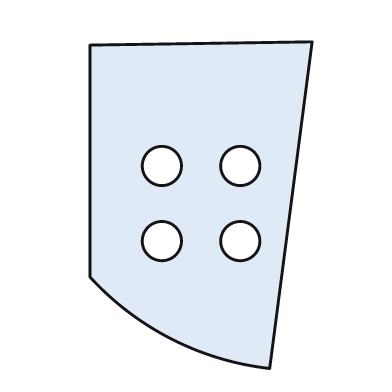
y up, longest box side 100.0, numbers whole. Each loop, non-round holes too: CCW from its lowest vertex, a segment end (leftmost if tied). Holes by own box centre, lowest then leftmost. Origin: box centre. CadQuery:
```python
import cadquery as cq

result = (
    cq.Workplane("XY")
    .moveTo(21.0, -50.0)
    .lineTo(34.0, 50.0)
    .lineTo(-34.0, 49.0)
    .lineTo(-34.0, -22.0)
    .threePointArc((-9.0, -41.0), (21.0, -50.0))
    .close()
    .moveTo(-12.0, -11.0)
    .circle(6.0)
    .moveTo(12.0, -11.0)
    .circle(6.0)
    .moveTo(-12.0, 12.0)
    .circle(6.0)
    .moveTo(12.0, 12.0)
    .circle(6.0)
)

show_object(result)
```